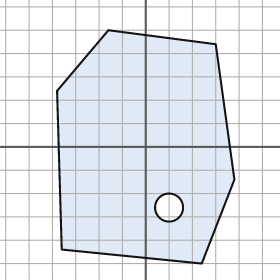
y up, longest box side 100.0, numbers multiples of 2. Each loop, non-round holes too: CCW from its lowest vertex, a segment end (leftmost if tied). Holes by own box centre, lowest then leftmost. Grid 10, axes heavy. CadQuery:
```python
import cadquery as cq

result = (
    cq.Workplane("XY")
    .moveTo(24.0, -50.0)
    .lineTo(38.0, -14.0)
    .lineTo(30.0, 44.0)
    .lineTo(-16.0, 50.0)
    .lineTo(-38.0, 24.0)
    .lineTo(-36.0, -44.0)
    .close()
    .moveTo(10.0, -26.0)
    .circle(6.0)
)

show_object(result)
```